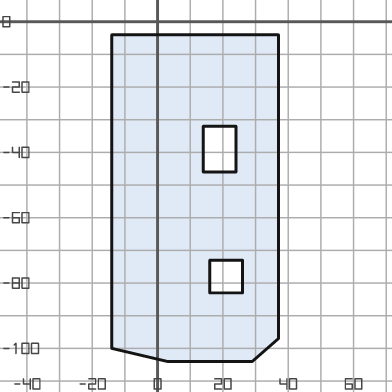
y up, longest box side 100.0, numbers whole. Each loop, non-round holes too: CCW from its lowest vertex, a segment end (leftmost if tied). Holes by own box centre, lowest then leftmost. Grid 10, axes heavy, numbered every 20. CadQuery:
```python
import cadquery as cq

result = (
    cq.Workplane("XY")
    .moveTo(3.0, -104.0)
    .lineTo(29.0, -104.0)
    .lineTo(37.0, -97.0)
    .lineTo(37.0, -4.0)
    .lineTo(-14.0, -4.0)
    .lineTo(-14.0, -100.0)
    .close()
    .moveTo(16.0, -83.0)
    .lineTo(26.0, -83.0)
    .lineTo(26.0, -73.0)
    .lineTo(16.0, -73.0)
    .close()
    .moveTo(14.0, -46.0)
    .lineTo(24.0, -46.0)
    .lineTo(24.0, -32.0)
    .lineTo(14.0, -32.0)
    .close()
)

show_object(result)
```